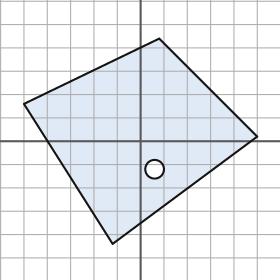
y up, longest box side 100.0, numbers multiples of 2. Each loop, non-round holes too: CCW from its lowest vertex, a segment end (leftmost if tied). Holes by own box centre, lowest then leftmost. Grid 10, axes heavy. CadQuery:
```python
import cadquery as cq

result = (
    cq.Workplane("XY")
    .moveTo(-12.0, -44.0)
    .lineTo(50.0, 2.0)
    .lineTo(8.0, 44.0)
    .lineTo(-50.0, 16.0)
    .close()
    .moveTo(6.0, -12.0)
    .circle(4.0)
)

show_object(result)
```